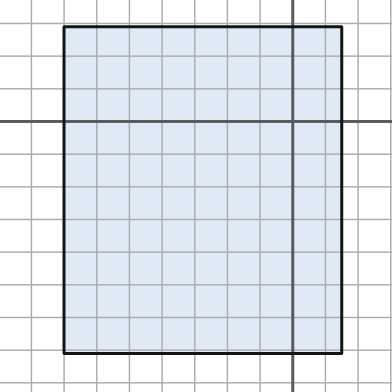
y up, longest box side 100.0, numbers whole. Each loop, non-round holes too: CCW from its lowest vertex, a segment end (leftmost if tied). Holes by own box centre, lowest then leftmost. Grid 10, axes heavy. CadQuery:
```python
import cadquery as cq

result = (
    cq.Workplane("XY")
    .moveTo(-70.0, -71.0)
    .lineTo(15.0, -71.0)
    .lineTo(15.0, 29.0)
    .lineTo(-70.0, 29.0)
    .close()
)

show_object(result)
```